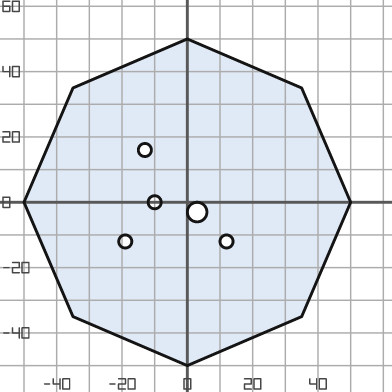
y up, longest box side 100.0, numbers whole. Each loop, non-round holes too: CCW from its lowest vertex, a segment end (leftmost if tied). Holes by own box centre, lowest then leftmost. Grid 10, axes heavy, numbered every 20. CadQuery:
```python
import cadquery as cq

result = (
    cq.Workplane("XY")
    .moveTo(0.0, -50.0)
    .lineTo(35.0, -35.0)
    .lineTo(50.0, 0.0)
    .lineTo(35.0, 35.0)
    .lineTo(0.0, 50.0)
    .lineTo(-35.0, 35.0)
    .lineTo(-50.0, 0.0)
    .lineTo(-35.0, -35.0)
    .close()
    .moveTo(-19.0, -12.0)
    .circle(2.0)
    .moveTo(12.0, -12.0)
    .circle(2.0)
    .moveTo(3.0, -3.0)
    .circle(3.0)
    .moveTo(-10.0, 0.0)
    .circle(2.0)
    .moveTo(-13.0, 16.0)
    .circle(2.0)
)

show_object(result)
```